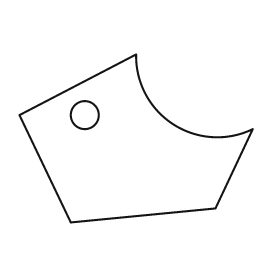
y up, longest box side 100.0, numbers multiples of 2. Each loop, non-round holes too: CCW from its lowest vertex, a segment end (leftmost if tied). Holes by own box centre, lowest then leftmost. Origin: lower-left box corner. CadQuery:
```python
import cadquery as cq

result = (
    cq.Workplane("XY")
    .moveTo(22.0, 0.0)
    .lineTo(84.0, 6.0)
    .lineTo(100.0, 40.0)
    .threePointArc((66.0, 42.0), (50.0, 72.0))
    .lineTo(0.0, 46.0)
    .close()
    .moveTo(28.0, 46.0)
    .circle(6.0)
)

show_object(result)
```